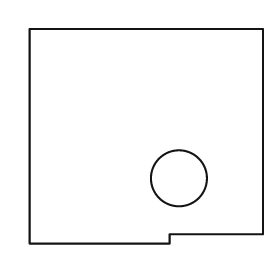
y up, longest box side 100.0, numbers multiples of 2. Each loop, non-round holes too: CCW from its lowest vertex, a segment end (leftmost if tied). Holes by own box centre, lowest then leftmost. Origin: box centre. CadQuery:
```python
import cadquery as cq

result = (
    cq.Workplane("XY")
    .moveTo(-50.0, -46.0)
    .lineTo(10.0, -46.0)
    .lineTo(10.0, -42.0)
    .lineTo(50.0, -42.0)
    .lineTo(50.0, 46.0)
    .lineTo(-50.0, 46.0)
    .close()
    .moveTo(14.0, -18.0)
    .circle(12.0)
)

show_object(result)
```